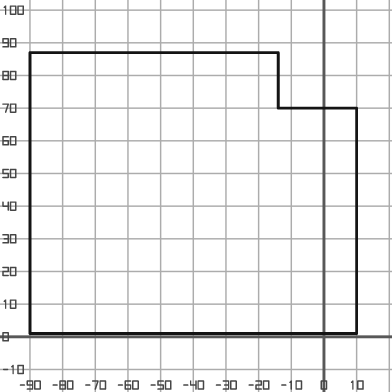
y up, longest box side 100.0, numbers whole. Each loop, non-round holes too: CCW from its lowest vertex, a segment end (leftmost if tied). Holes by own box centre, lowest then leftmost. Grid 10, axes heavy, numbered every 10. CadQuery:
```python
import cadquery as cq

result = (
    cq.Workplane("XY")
    .moveTo(-90.0, 1.0)
    .lineTo(10.0, 1.0)
    .lineTo(10.0, 70.0)
    .lineTo(-14.0, 70.0)
    .lineTo(-14.0, 87.0)
    .lineTo(-90.0, 87.0)
    .close()
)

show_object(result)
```